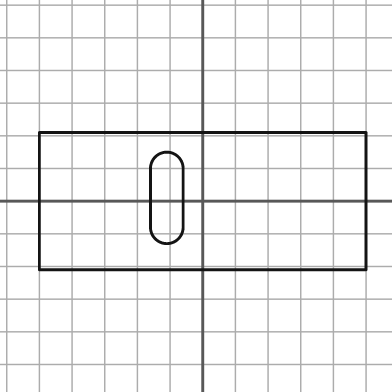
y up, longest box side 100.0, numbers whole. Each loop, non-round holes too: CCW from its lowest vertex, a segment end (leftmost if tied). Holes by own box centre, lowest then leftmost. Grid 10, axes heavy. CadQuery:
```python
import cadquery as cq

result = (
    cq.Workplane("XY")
    .moveTo(-50.0, -21.0)
    .lineTo(50.0, -21.0)
    .lineTo(50.0, 21.0)
    .lineTo(-50.0, 21.0)
    .close()
    .moveTo(-16.0, -8.0)
    .threePointArc((-11.0, -13.0), (-6.0, -8.0))
    .lineTo(-6.0, 10.0)
    .threePointArc((-11.0, 15.0), (-16.0, 10.0))
    .close()
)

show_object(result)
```